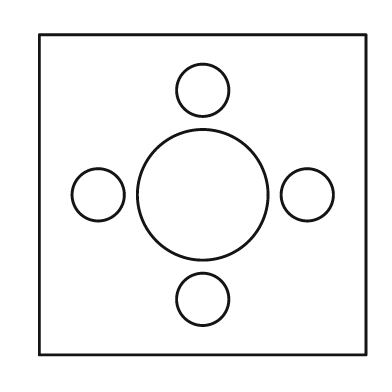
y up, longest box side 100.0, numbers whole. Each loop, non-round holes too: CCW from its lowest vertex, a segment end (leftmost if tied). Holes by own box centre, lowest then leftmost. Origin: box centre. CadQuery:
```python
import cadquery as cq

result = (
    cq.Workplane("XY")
    .moveTo(-50.0, -49.0)
    .lineTo(50.0, -49.0)
    .lineTo(50.0, 49.0)
    .lineTo(-50.0, 49.0)
    .close()
    .moveTo(0.0, -32.0)
    .circle(8.0)
    .moveTo(-32.0, 0.0)
    .circle(8.0)
    .moveTo(0.0, 0.0)
    .circle(20.0)
    .moveTo(32.0, 0.0)
    .circle(8.0)
    .moveTo(0.0, 32.0)
    .circle(8.0)
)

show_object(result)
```